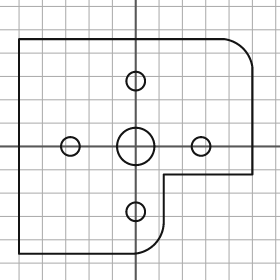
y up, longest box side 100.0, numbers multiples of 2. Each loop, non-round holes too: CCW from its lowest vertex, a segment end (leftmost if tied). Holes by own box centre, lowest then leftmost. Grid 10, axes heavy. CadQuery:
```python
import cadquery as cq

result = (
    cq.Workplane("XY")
    .moveTo(-50.0, -46.0)
    .lineTo(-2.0, -46.0)
    .threePointArc((8.0, -42.0), (12.0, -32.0))
    .lineTo(12.0, -12.0)
    .lineTo(50.0, -12.0)
    .lineTo(50.0, 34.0)
    .threePointArc((46.0, 42.0), (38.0, 46.0))
    .lineTo(-50.0, 46.0)
    .close()
    .moveTo(0.0, -28.0)
    .circle(4.0)
    .moveTo(-28.0, 0.0)
    .circle(4.0)
    .moveTo(0.0, 0.0)
    .circle(8.0)
    .moveTo(28.0, 0.0)
    .circle(4.0)
    .moveTo(0.0, 28.0)
    .circle(4.0)
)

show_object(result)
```